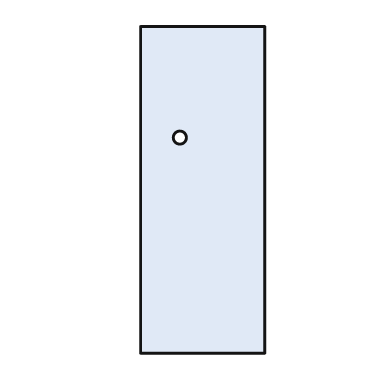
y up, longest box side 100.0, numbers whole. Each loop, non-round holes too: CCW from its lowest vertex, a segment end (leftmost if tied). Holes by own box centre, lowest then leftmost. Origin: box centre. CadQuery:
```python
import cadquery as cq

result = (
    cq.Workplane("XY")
    .moveTo(-19.0, -50.0)
    .lineTo(19.0, -50.0)
    .lineTo(19.0, 50.0)
    .lineTo(-19.0, 50.0)
    .close()
    .moveTo(-7.0, 16.0)
    .circle(2.0)
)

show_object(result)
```